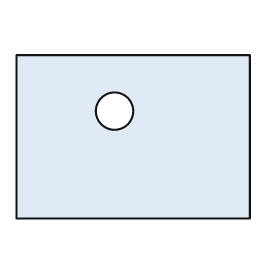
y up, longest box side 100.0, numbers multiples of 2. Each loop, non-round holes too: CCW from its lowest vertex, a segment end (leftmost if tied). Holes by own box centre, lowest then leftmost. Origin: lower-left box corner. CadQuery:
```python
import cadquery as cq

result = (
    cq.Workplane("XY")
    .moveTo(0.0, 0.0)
    .lineTo(100.0, 0.0)
    .lineTo(100.0, 70.0)
    .lineTo(0.0, 70.0)
    .close()
    .moveTo(42.0, 46.0)
    .circle(8.0)
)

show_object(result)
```